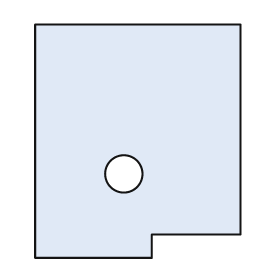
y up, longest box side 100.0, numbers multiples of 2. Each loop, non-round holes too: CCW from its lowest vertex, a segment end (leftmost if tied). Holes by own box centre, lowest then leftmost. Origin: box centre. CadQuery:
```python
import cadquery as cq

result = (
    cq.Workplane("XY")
    .moveTo(-44.0, -50.0)
    .lineTo(6.0, -50.0)
    .lineTo(6.0, -40.0)
    .lineTo(44.0, -40.0)
    .lineTo(44.0, 50.0)
    .lineTo(-44.0, 50.0)
    .close()
    .moveTo(-6.0, -14.0)
    .circle(8.0)
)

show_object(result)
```